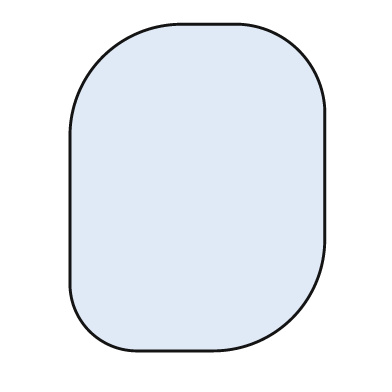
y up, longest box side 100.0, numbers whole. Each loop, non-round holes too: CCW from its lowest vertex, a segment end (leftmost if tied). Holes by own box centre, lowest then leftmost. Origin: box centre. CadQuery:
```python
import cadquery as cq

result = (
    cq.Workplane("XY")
    .moveTo(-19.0, -50.0)
    .lineTo(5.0, -50.0)
    .threePointArc((29.0, -40.0), (39.0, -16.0))
    .lineTo(39.0, 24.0)
    .threePointArc((31.0, 42.0), (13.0, 50.0))
    .lineTo(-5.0, 50.0)
    .threePointArc((-29.0, 40.0), (-39.0, 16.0))
    .lineTo(-39.0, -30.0)
    .threePointArc((-33.0, -44.0), (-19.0, -50.0))
    .close()
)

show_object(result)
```